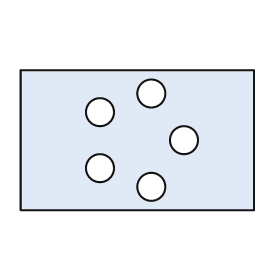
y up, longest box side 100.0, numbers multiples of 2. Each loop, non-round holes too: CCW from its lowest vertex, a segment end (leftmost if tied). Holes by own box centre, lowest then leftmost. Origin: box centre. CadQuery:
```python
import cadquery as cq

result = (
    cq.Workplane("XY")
    .moveTo(-50.0, -30.0)
    .lineTo(50.0, -30.0)
    .lineTo(50.0, 30.0)
    .lineTo(-50.0, 30.0)
    .close()
    .moveTo(6.0, -20.0)
    .circle(6.0)
    .moveTo(-16.0, -12.0)
    .circle(6.0)
    .moveTo(20.0, 0.0)
    .circle(6.0)
    .moveTo(-16.0, 12.0)
    .circle(6.0)
    .moveTo(6.0, 20.0)
    .circle(6.0)
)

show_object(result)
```